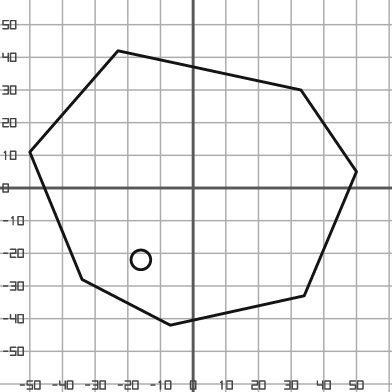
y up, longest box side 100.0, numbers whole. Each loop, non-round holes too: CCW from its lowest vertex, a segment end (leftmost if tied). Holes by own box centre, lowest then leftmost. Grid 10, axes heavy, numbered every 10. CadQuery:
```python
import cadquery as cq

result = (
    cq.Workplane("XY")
    .moveTo(-7.0, -42.0)
    .lineTo(34.0, -33.0)
    .lineTo(50.0, 5.0)
    .lineTo(33.0, 30.0)
    .lineTo(-23.0, 42.0)
    .lineTo(-50.0, 11.0)
    .lineTo(-34.0, -28.0)
    .close()
    .moveTo(-16.0, -22.0)
    .circle(3.0)
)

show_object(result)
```